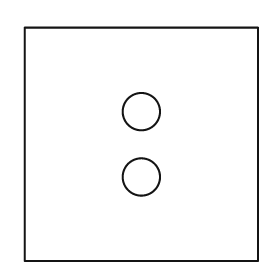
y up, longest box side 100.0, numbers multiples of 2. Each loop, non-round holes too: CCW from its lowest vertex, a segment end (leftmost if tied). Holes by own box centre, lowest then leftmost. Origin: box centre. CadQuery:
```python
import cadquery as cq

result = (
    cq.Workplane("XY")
    .moveTo(-50.0, -50.0)
    .lineTo(50.0, -50.0)
    .lineTo(50.0, 50.0)
    .lineTo(-50.0, 50.0)
    .close()
    .moveTo(0.0, -14.0)
    .circle(8.0)
    .moveTo(0.0, 14.0)
    .circle(8.0)
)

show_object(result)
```